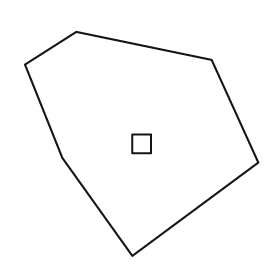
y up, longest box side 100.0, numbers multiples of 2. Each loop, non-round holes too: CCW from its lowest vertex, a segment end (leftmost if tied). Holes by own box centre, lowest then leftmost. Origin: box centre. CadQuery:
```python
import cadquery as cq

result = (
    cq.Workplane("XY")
    .moveTo(-4.0, -48.0)
    .lineTo(50.0, -8.0)
    .lineTo(30.0, 36.0)
    .lineTo(-28.0, 48.0)
    .lineTo(-50.0, 34.0)
    .lineTo(-34.0, -6.0)
    .close()
    .moveTo(-4.0, -4.0)
    .lineTo(4.0, -4.0)
    .lineTo(4.0, 4.0)
    .lineTo(-4.0, 4.0)
    .close()
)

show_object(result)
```